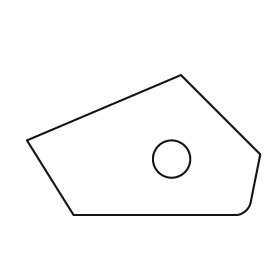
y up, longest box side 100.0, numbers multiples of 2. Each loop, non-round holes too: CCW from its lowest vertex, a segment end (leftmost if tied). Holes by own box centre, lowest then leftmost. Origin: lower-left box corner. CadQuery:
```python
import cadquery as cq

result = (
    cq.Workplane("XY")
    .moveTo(20.0, 0.0)
    .lineTo(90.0, 0.0)
    .threePointArc((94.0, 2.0), (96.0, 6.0))
    .lineTo(100.0, 26.0)
    .lineTo(66.0, 60.0)
    .lineTo(0.0, 32.0)
    .close()
    .moveTo(62.0, 24.0)
    .circle(8.0)
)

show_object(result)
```